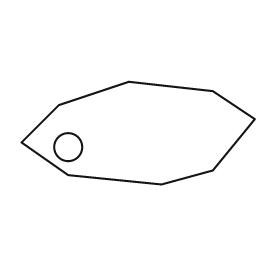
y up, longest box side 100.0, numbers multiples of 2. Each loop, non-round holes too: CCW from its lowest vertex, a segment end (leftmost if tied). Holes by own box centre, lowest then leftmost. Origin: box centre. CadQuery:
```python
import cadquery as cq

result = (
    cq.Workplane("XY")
    .moveTo(10.0, -22.0)
    .lineTo(32.0, -16.0)
    .lineTo(50.0, 6.0)
    .lineTo(32.0, 18.0)
    .lineTo(-4.0, 22.0)
    .lineTo(-34.0, 12.0)
    .lineTo(-50.0, -4.0)
    .lineTo(-30.0, -18.0)
    .close()
    .moveTo(-30.0, -6.0)
    .circle(6.0)
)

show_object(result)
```